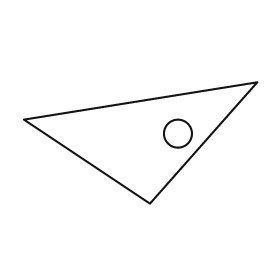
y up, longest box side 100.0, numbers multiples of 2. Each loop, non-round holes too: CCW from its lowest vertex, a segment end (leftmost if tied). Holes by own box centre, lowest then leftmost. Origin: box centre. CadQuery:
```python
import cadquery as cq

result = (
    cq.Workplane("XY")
    .moveTo(4.0, -26.0)
    .lineTo(50.0, 26.0)
    .lineTo(-50.0, 10.0)
    .close()
    .moveTo(16.0, 4.0)
    .circle(6.0)
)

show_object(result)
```